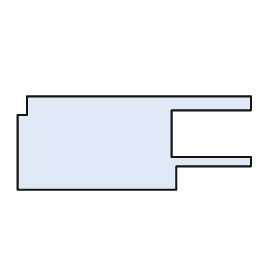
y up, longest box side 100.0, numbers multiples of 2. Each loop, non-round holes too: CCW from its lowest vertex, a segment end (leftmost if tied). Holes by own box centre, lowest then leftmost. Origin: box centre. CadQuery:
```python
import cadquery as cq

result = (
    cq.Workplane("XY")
    .moveTo(-50.0, -20.0)
    .lineTo(18.0, -20.0)
    .lineTo(18.0, -10.0)
    .lineTo(50.0, -10.0)
    .lineTo(50.0, -6.0)
    .lineTo(16.0, -6.0)
    .lineTo(16.0, 14.0)
    .lineTo(50.0, 14.0)
    .lineTo(50.0, 20.0)
    .lineTo(-46.0, 20.0)
    .lineTo(-46.0, 12.0)
    .lineTo(-50.0, 12.0)
    .close()
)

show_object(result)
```